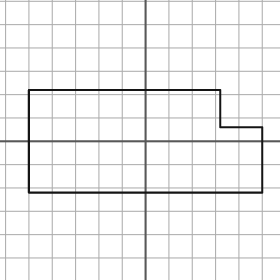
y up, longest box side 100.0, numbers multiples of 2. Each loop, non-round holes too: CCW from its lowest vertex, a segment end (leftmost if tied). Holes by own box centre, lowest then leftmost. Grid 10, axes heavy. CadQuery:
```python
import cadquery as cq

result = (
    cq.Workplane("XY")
    .moveTo(-50.0, -22.0)
    .lineTo(50.0, -22.0)
    .lineTo(50.0, 6.0)
    .lineTo(32.0, 6.0)
    .lineTo(32.0, 22.0)
    .lineTo(-50.0, 22.0)
    .close()
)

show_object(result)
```